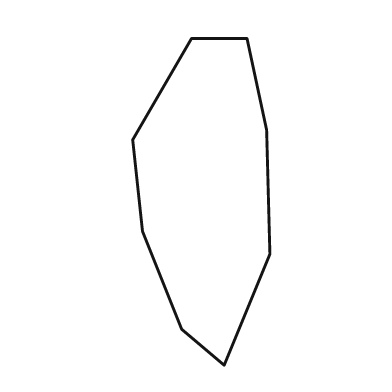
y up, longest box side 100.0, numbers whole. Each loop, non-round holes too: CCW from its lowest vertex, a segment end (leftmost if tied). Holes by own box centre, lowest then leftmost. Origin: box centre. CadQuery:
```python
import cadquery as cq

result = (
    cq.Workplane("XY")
    .moveTo(7.0, -50.0)
    .lineTo(21.0, -16.0)
    .lineTo(20.0, 22.0)
    .lineTo(14.0, 50.0)
    .lineTo(-3.0, 50.0)
    .lineTo(-21.0, 19.0)
    .lineTo(-18.0, -9.0)
    .lineTo(-6.0, -39.0)
    .close()
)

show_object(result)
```